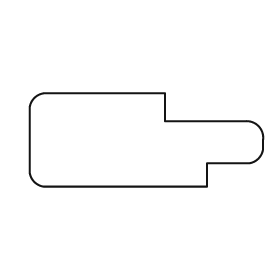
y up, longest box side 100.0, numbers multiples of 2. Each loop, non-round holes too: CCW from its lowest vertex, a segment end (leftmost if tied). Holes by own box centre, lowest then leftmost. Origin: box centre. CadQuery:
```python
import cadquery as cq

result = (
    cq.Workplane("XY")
    .moveTo(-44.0, -20.0)
    .lineTo(26.0, -20.0)
    .lineTo(26.0, -10.0)
    .lineTo(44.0, -10.0)
    .threePointArc((48.0, -8.0), (50.0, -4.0))
    .lineTo(50.0, 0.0)
    .threePointArc((48.0, 6.0), (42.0, 8.0))
    .lineTo(8.0, 8.0)
    .lineTo(8.0, 20.0)
    .lineTo(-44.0, 20.0)
    .threePointArc((-48.0, 18.0), (-50.0, 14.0))
    .lineTo(-50.0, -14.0)
    .threePointArc((-48.0, -18.0), (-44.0, -20.0))
    .close()
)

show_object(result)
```